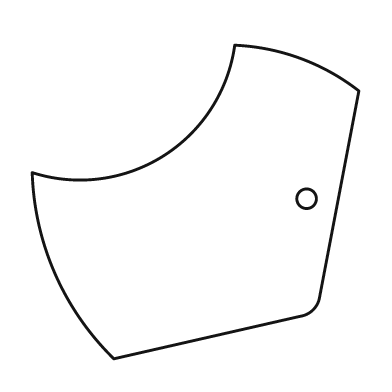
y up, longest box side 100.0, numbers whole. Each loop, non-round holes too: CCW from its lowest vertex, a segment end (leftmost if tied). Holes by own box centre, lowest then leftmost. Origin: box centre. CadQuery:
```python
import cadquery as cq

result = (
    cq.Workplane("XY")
    .moveTo(-25.0, -48.0)
    .lineTo(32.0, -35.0)
    .threePointArc((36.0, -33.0), (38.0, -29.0))
    .lineTo(50.0, 34.0)
    .threePointArc((32.0, 44.0), (12.0, 48.0))
    .threePointArc((-10.0, 14.0), (-50.0, 9.0))
    .threePointArc((-43.0, -22.0), (-25.0, -48.0))
    .close()
    .moveTo(34.0, 1.0)
    .circle(3.0)
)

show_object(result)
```